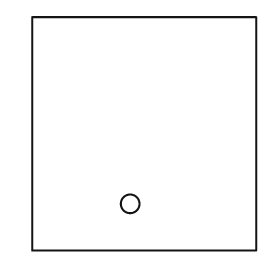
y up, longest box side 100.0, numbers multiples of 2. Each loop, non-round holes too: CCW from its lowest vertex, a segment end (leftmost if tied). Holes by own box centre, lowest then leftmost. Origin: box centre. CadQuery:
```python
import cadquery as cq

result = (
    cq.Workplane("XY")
    .moveTo(-48.0, -50.0)
    .lineTo(48.0, -50.0)
    .lineTo(48.0, 50.0)
    .lineTo(-48.0, 50.0)
    .close()
    .moveTo(-6.0, -30.0)
    .circle(4.0)
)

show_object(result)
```